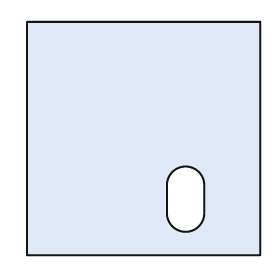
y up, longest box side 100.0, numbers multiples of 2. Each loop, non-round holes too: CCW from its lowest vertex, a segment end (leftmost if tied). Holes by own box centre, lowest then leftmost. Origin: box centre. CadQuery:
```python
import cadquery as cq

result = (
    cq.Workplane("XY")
    .moveTo(-50.0, -50.0)
    .lineTo(50.0, -50.0)
    .lineTo(50.0, 50.0)
    .lineTo(-50.0, 50.0)
    .close()
    .moveTo(10.0, -32.0)
    .threePointArc((18.0, -40.0), (26.0, -32.0))
    .lineTo(26.0, -20.0)
    .threePointArc((18.0, -12.0), (10.0, -20.0))
    .close()
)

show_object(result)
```